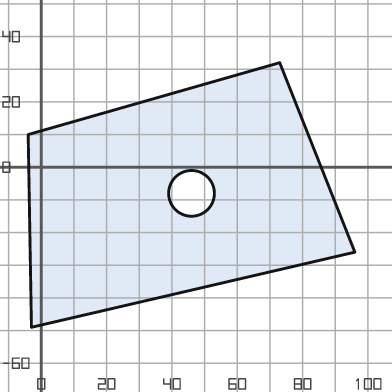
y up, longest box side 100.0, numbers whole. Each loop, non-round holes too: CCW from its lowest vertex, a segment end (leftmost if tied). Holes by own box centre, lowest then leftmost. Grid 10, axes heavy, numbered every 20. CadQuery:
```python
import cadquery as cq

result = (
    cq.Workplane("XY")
    .moveTo(-3.0, -49.0)
    .lineTo(96.0, -26.0)
    .lineTo(73.0, 32.0)
    .lineTo(-4.0, 10.0)
    .close()
    .moveTo(46.0, -8.0)
    .circle(7.0)
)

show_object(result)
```